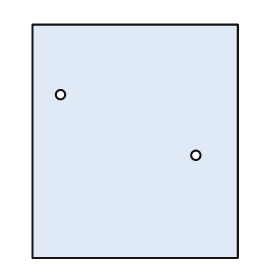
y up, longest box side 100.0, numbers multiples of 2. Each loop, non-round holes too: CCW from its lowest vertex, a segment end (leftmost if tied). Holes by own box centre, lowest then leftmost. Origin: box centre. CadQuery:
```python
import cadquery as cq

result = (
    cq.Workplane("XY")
    .moveTo(-44.0, -50.0)
    .lineTo(44.0, -50.0)
    .lineTo(44.0, 50.0)
    .lineTo(-44.0, 50.0)
    .close()
    .moveTo(26.0, -6.0)
    .circle(2.0)
    .moveTo(-32.0, 20.0)
    .circle(2.0)
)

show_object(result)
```